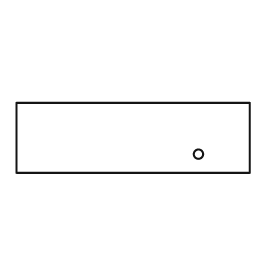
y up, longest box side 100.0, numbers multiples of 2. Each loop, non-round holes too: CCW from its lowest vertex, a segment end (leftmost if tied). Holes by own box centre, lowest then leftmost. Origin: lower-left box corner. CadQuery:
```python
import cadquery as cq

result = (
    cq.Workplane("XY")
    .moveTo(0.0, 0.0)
    .lineTo(100.0, 0.0)
    .lineTo(100.0, 30.0)
    .lineTo(0.0, 30.0)
    .close()
    .moveTo(78.0, 8.0)
    .circle(2.0)
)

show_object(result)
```